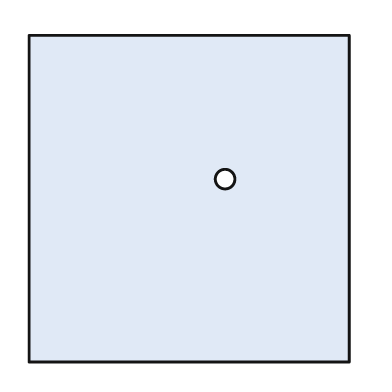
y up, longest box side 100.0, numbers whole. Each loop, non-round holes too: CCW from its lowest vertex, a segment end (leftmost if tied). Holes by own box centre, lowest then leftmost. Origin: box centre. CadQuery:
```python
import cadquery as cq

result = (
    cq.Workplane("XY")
    .moveTo(-49.0, -50.0)
    .lineTo(49.0, -50.0)
    .lineTo(49.0, 50.0)
    .lineTo(-49.0, 50.0)
    .close()
    .moveTo(11.0, 6.0)
    .circle(3.0)
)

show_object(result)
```